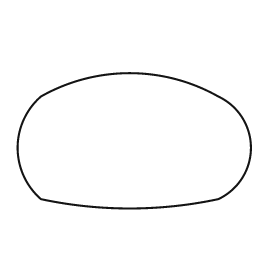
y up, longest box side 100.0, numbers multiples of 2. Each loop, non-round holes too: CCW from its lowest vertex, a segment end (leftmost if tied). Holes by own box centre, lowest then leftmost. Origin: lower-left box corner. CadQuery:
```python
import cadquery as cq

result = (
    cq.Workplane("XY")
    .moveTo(10.0, 4.0)
    .threePointArc((48.0, 0.0), (86.0, 4.0))
    .threePointArc((100.0, 26.0), (86.0, 48.0))
    .threePointArc((48.0, 58.0), (10.0, 48.0))
    .threePointArc((0.0, 26.0), (10.0, 4.0))
    .close()
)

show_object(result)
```